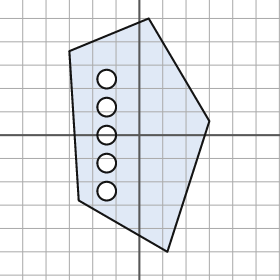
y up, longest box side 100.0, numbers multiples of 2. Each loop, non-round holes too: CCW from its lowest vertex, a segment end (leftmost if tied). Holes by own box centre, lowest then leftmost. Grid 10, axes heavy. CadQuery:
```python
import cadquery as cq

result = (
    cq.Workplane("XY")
    .moveTo(12.0, -50.0)
    .lineTo(30.0, 6.0)
    .lineTo(4.0, 50.0)
    .lineTo(-30.0, 36.0)
    .lineTo(-26.0, -28.0)
    .close()
    .moveTo(-14.0, -24.0)
    .circle(4.0)
    .moveTo(-14.0, -12.0)
    .circle(4.0)
    .moveTo(-14.0, 0.0)
    .circle(4.0)
    .moveTo(-14.0, 12.0)
    .circle(4.0)
    .moveTo(-14.0, 24.0)
    .circle(4.0)
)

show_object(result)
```